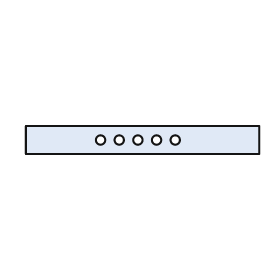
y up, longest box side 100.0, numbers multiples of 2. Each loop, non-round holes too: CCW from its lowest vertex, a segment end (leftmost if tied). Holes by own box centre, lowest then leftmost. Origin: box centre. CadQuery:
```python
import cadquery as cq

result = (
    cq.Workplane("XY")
    .moveTo(-50.0, -6.0)
    .lineTo(50.0, -6.0)
    .lineTo(50.0, 6.0)
    .lineTo(-50.0, 6.0)
    .close()
    .moveTo(-18.0, 0.0)
    .circle(2.0)
    .moveTo(-10.0, 0.0)
    .circle(2.0)
    .moveTo(-2.0, 0.0)
    .circle(2.0)
    .moveTo(6.0, 0.0)
    .circle(2.0)
    .moveTo(14.0, 0.0)
    .circle(2.0)
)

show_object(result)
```